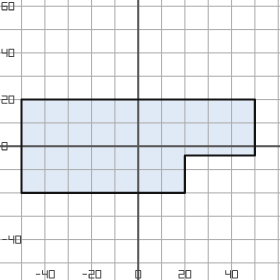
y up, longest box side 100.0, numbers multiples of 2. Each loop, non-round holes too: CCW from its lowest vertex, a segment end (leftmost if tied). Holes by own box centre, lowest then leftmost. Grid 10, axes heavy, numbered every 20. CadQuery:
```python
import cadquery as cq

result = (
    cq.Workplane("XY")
    .moveTo(-50.0, -20.0)
    .lineTo(20.0, -20.0)
    .lineTo(20.0, -4.0)
    .lineTo(50.0, -4.0)
    .lineTo(50.0, 20.0)
    .lineTo(-50.0, 20.0)
    .close()
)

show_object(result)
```